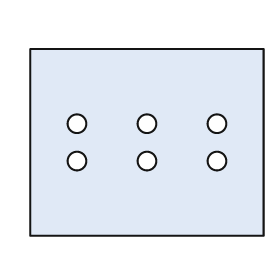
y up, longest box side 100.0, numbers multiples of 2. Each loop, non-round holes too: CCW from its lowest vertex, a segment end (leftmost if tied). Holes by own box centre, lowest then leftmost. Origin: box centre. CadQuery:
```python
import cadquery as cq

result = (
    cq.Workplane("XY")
    .moveTo(-50.0, -40.0)
    .lineTo(50.0, -40.0)
    .lineTo(50.0, 40.0)
    .lineTo(-50.0, 40.0)
    .close()
    .moveTo(-30.0, -8.0)
    .circle(4.0)
    .moveTo(0.0, -8.0)
    .circle(4.0)
    .moveTo(30.0, -8.0)
    .circle(4.0)
    .moveTo(-30.0, 8.0)
    .circle(4.0)
    .moveTo(0.0, 8.0)
    .circle(4.0)
    .moveTo(30.0, 8.0)
    .circle(4.0)
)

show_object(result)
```